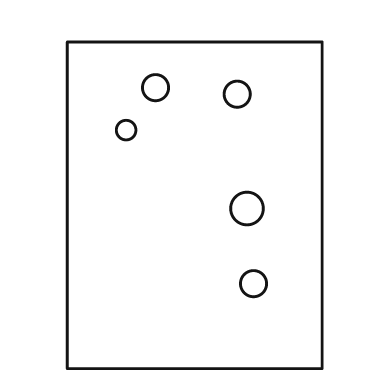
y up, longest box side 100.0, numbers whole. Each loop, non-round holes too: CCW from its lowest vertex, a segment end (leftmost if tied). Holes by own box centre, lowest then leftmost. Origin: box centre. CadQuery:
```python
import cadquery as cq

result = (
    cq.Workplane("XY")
    .moveTo(-39.0, -50.0)
    .lineTo(39.0, -50.0)
    .lineTo(39.0, 50.0)
    .lineTo(-39.0, 50.0)
    .close()
    .moveTo(18.0, -24.0)
    .circle(4.0)
    .moveTo(16.0, -1.0)
    .circle(5.0)
    .moveTo(-21.0, 23.0)
    .circle(3.0)
    .moveTo(13.0, 34.0)
    .circle(4.0)
    .moveTo(-12.0, 36.0)
    .circle(4.0)
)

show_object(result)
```